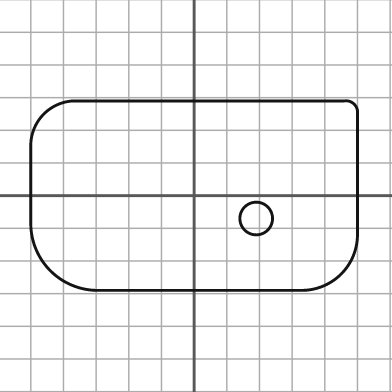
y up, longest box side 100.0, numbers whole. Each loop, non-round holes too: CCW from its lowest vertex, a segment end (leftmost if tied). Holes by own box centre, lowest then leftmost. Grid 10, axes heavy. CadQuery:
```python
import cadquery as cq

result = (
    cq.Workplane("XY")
    .moveTo(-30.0, -29.0)
    .lineTo(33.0, -29.0)
    .threePointArc((45.0, -24.0), (50.0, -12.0))
    .lineTo(50.0, 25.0)
    .threePointArc((49.0, 28.0), (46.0, 29.0))
    .lineTo(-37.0, 29.0)
    .threePointArc((-46.0, 25.0), (-50.0, 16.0))
    .lineTo(-50.0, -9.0)
    .threePointArc((-44.0, -23.0), (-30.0, -29.0))
    .close()
    .moveTo(19.0, -7.0)
    .circle(5.0)
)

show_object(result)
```